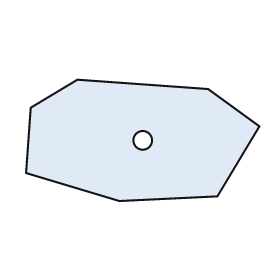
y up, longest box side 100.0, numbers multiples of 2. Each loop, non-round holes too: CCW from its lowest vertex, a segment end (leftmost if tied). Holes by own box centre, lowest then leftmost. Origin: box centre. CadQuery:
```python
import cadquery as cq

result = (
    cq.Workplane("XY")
    .moveTo(-10.0, -26.0)
    .lineTo(32.0, -24.0)
    .lineTo(50.0, 6.0)
    .lineTo(28.0, 22.0)
    .lineTo(-28.0, 26.0)
    .lineTo(-48.0, 14.0)
    .lineTo(-50.0, -14.0)
    .close()
    .moveTo(0.0, 0.0)
    .circle(4.0)
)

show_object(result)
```